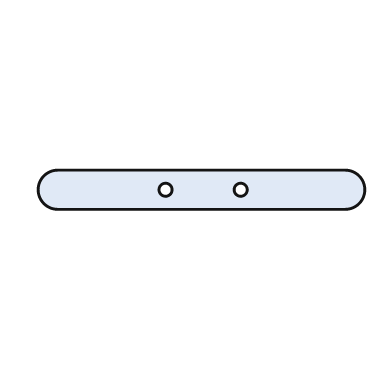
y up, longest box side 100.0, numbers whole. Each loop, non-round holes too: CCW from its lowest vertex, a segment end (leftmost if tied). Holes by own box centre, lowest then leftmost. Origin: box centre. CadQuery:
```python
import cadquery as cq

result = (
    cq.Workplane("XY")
    .moveTo(-44.0, -6.0)
    .lineTo(44.0, -6.0)
    .threePointArc((50.0, 0.0), (44.0, 6.0))
    .lineTo(-44.0, 6.0)
    .threePointArc((-50.0, 0.0), (-44.0, -6.0))
    .close()
    .moveTo(-11.0, 0.0)
    .circle(2.0)
    .moveTo(12.0, 0.0)
    .circle(2.0)
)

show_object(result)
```